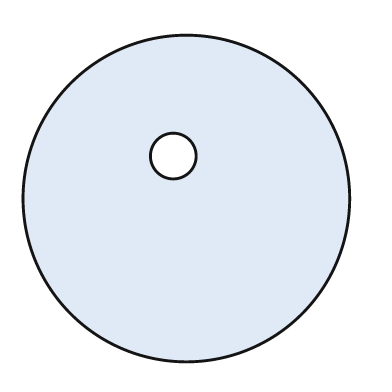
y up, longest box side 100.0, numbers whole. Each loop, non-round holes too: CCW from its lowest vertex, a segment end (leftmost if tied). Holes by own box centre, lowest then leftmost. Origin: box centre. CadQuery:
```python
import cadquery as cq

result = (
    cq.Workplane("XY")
    .moveTo(0.0, 0.0)
    .circle(50.0)
    .moveTo(-4.0, 13.0)
    .circle(7.0)
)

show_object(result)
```